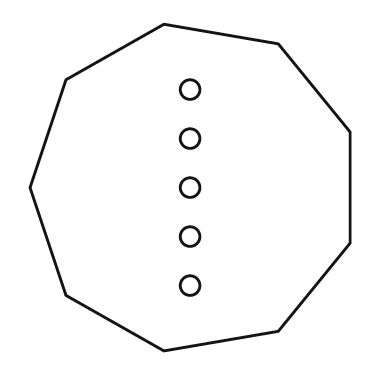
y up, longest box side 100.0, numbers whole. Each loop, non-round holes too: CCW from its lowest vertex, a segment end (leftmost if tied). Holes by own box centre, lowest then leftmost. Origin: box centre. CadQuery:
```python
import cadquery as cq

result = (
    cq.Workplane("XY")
    .moveTo(-8.0, -50.0)
    .lineTo(27.0, -44.0)
    .lineTo(49.0, -17.0)
    .lineTo(49.0, 17.0)
    .lineTo(27.0, 44.0)
    .lineTo(-8.0, 50.0)
    .lineTo(-38.0, 33.0)
    .lineTo(-49.0, 0.0)
    .lineTo(-38.0, -33.0)
    .close()
    .moveTo(0.0, -30.0)
    .circle(3.0)
    .moveTo(0.0, -15.0)
    .circle(3.0)
    .moveTo(0.0, 0.0)
    .circle(3.0)
    .moveTo(0.0, 15.0)
    .circle(3.0)
    .moveTo(0.0, 30.0)
    .circle(3.0)
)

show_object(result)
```